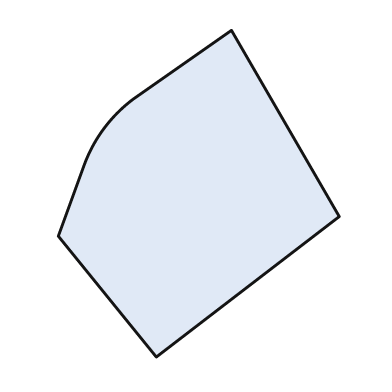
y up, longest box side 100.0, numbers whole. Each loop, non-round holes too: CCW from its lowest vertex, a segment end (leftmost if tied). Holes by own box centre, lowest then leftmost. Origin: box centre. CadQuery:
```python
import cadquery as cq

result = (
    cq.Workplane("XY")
    .moveTo(-13.0, -50.0)
    .lineTo(43.0, -7.0)
    .lineTo(10.0, 50.0)
    .lineTo(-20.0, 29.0)
    .threePointArc((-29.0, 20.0), (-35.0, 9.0))
    .lineTo(-43.0, -13.0)
    .close()
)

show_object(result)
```